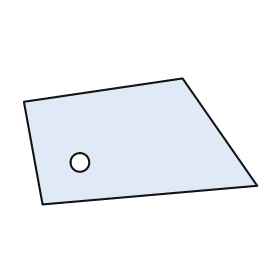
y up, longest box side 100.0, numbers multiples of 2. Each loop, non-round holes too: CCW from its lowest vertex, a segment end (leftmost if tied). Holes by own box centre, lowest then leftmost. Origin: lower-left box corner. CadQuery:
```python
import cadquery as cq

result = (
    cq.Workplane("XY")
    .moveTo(8.0, 0.0)
    .lineTo(100.0, 8.0)
    .lineTo(68.0, 54.0)
    .lineTo(0.0, 44.0)
    .close()
    .moveTo(24.0, 18.0)
    .circle(4.0)
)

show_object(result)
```